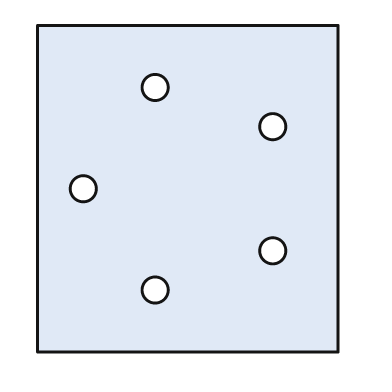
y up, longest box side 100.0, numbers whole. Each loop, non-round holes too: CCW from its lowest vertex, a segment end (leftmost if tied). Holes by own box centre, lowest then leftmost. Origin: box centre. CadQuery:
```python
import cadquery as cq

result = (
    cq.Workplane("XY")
    .moveTo(-46.0, -50.0)
    .lineTo(46.0, -50.0)
    .lineTo(46.0, 50.0)
    .lineTo(-46.0, 50.0)
    .close()
    .moveTo(-10.0, -31.0)
    .circle(4.0)
    .moveTo(26.0, -19.0)
    .circle(4.0)
    .moveTo(-32.0, 0.0)
    .circle(4.0)
    .moveTo(26.0, 19.0)
    .circle(4.0)
    .moveTo(-10.0, 31.0)
    .circle(4.0)
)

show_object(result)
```